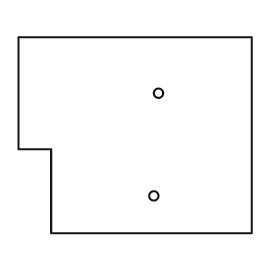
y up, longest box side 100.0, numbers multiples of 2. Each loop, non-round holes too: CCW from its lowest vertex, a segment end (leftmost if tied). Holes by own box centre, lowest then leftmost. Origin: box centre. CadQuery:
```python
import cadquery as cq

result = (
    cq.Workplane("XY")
    .moveTo(-36.0, -42.0)
    .lineTo(50.0, -42.0)
    .lineTo(50.0, 42.0)
    .lineTo(-50.0, 42.0)
    .lineTo(-50.0, -6.0)
    .lineTo(-36.0, -6.0)
    .close()
    .moveTo(8.0, -26.0)
    .circle(2.0)
    .moveTo(10.0, 18.0)
    .circle(2.0)
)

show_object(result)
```